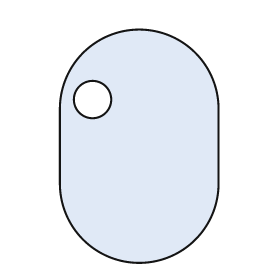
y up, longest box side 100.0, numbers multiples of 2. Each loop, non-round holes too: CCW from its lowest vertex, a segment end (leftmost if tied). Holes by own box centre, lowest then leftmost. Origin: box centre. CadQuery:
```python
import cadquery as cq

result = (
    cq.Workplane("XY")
    .moveTo(-34.0, -16.0)
    .threePointArc((0.0, -50.0), (34.0, -16.0))
    .lineTo(34.0, 16.0)
    .threePointArc((0.0, 50.0), (-34.0, 16.0))
    .close()
    .moveTo(-20.0, 20.0)
    .circle(8.0)
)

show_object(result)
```